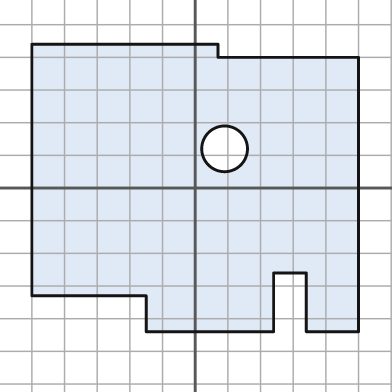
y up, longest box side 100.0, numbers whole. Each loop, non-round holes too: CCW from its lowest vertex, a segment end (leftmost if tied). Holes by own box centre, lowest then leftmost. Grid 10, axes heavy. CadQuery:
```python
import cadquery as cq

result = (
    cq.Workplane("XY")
    .moveTo(-15.0, -44.0)
    .lineTo(24.0, -44.0)
    .lineTo(24.0, -26.0)
    .lineTo(34.0, -26.0)
    .lineTo(34.0, -44.0)
    .lineTo(50.0, -44.0)
    .lineTo(50.0, 40.0)
    .lineTo(7.0, 40.0)
    .lineTo(7.0, 44.0)
    .lineTo(-50.0, 44.0)
    .lineTo(-50.0, -33.0)
    .lineTo(-15.0, -33.0)
    .close()
    .moveTo(9.0, 12.0)
    .circle(7.0)
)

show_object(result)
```